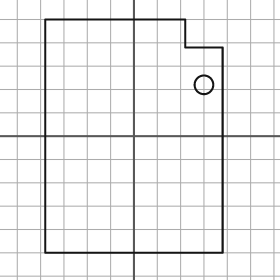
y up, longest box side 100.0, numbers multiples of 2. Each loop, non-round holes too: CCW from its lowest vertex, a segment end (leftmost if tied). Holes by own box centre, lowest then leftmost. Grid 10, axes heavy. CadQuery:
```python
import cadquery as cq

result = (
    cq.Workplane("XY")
    .moveTo(-38.0, -50.0)
    .lineTo(38.0, -50.0)
    .lineTo(38.0, 38.0)
    .lineTo(22.0, 38.0)
    .lineTo(22.0, 50.0)
    .lineTo(-38.0, 50.0)
    .close()
    .moveTo(30.0, 22.0)
    .circle(4.0)
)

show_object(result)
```